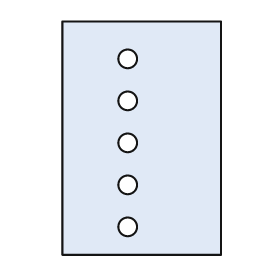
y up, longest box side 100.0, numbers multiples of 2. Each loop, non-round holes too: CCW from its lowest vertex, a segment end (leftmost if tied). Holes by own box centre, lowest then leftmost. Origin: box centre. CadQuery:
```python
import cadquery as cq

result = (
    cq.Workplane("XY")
    .moveTo(-34.0, -50.0)
    .lineTo(34.0, -50.0)
    .lineTo(34.0, 50.0)
    .lineTo(-34.0, 50.0)
    .close()
    .moveTo(-6.0, -38.0)
    .circle(4.0)
    .moveTo(-6.0, -20.0)
    .circle(4.0)
    .moveTo(-6.0, -2.0)
    .circle(4.0)
    .moveTo(-6.0, 16.0)
    .circle(4.0)
    .moveTo(-6.0, 34.0)
    .circle(4.0)
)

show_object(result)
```